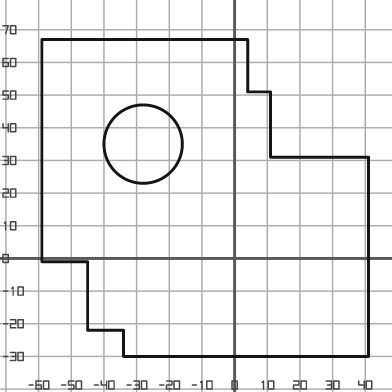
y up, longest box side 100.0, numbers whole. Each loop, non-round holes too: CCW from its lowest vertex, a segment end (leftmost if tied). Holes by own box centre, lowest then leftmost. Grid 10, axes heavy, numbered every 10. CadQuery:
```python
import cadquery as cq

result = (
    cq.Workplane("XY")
    .moveTo(-34.0, -30.0)
    .lineTo(41.0, -30.0)
    .lineTo(41.0, 31.0)
    .lineTo(11.0, 31.0)
    .lineTo(11.0, 51.0)
    .lineTo(4.0, 51.0)
    .lineTo(4.0, 67.0)
    .lineTo(-59.0, 67.0)
    .lineTo(-59.0, -1.0)
    .lineTo(-45.0, -1.0)
    .lineTo(-45.0, -22.0)
    .lineTo(-34.0, -22.0)
    .close()
    .moveTo(-28.0, 35.0)
    .circle(12.0)
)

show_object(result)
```